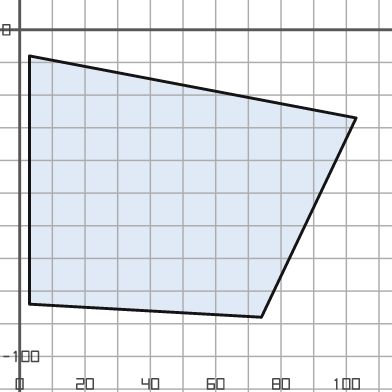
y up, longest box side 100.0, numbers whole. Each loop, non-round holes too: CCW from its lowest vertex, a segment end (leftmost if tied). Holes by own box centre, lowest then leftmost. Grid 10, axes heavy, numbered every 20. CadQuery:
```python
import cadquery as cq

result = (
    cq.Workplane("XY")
    .moveTo(74.0, -88.0)
    .lineTo(103.0, -27.0)
    .lineTo(3.0, -8.0)
    .lineTo(3.0, -84.0)
    .close()
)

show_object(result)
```